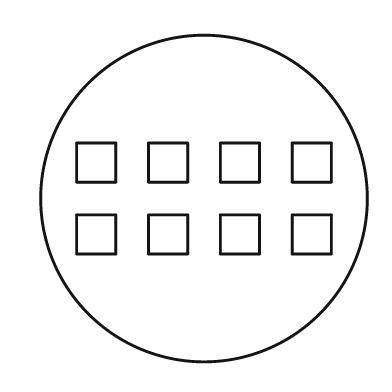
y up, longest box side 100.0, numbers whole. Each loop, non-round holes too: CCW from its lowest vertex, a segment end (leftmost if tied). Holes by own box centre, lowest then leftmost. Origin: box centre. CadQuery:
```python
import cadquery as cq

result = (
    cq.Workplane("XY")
    .moveTo(0.0, 0.0)
    .circle(50.0)
    .moveTo(-39.0, -17.0)
    .lineTo(-27.0, -17.0)
    .lineTo(-27.0, -5.0)
    .lineTo(-39.0, -5.0)
    .close()
    .moveTo(-17.0, -17.0)
    .lineTo(-5.0, -17.0)
    .lineTo(-5.0, -5.0)
    .lineTo(-17.0, -5.0)
    .close()
    .moveTo(5.0, -17.0)
    .lineTo(17.0, -17.0)
    .lineTo(17.0, -5.0)
    .lineTo(5.0, -5.0)
    .close()
    .moveTo(27.0, -17.0)
    .lineTo(39.0, -17.0)
    .lineTo(39.0, -5.0)
    .lineTo(27.0, -5.0)
    .close()
    .moveTo(-39.0, 5.0)
    .lineTo(-27.0, 5.0)
    .lineTo(-27.0, 17.0)
    .lineTo(-39.0, 17.0)
    .close()
    .moveTo(-17.0, 5.0)
    .lineTo(-5.0, 5.0)
    .lineTo(-5.0, 17.0)
    .lineTo(-17.0, 17.0)
    .close()
    .moveTo(5.0, 5.0)
    .lineTo(17.0, 5.0)
    .lineTo(17.0, 17.0)
    .lineTo(5.0, 17.0)
    .close()
    .moveTo(27.0, 5.0)
    .lineTo(39.0, 5.0)
    .lineTo(39.0, 17.0)
    .lineTo(27.0, 17.0)
    .close()
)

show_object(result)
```